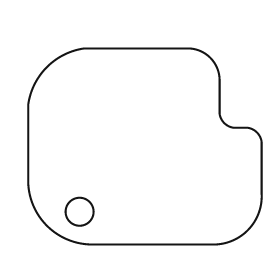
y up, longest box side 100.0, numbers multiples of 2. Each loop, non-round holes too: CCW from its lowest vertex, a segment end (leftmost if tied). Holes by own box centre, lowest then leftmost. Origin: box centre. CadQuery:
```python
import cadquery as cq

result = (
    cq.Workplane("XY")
    .moveTo(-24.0, -42.0)
    .lineTo(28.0, -42.0)
    .threePointArc((44.0, -36.0), (50.0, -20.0))
    .lineTo(50.0, 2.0)
    .threePointArc((48.0, 6.0), (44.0, 8.0))
    .lineTo(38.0, 8.0)
    .threePointArc((34.0, 10.0), (32.0, 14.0))
    .lineTo(32.0, 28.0)
    .threePointArc((28.0, 38.0), (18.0, 42.0))
    .lineTo(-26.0, 42.0)
    .threePointArc((-42.0, 34.0), (-50.0, 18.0))
    .lineTo(-50.0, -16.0)
    .threePointArc((-42.0, -34.0), (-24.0, -42.0))
    .close()
    .moveTo(-28.0, -28.0)
    .circle(6.0)
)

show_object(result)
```